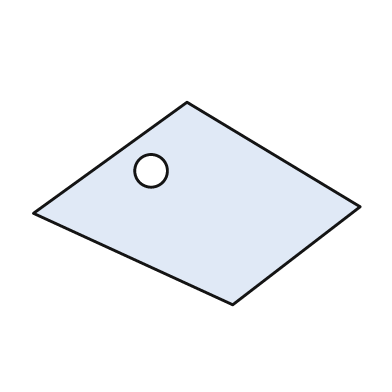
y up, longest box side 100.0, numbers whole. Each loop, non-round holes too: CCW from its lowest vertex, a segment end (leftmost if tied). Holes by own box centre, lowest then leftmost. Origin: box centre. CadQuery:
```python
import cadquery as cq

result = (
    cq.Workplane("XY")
    .moveTo(11.0, -31.0)
    .lineTo(50.0, -1.0)
    .lineTo(-3.0, 31.0)
    .lineTo(-50.0, -3.0)
    .close()
    .moveTo(-14.0, 10.0)
    .circle(5.0)
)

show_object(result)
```